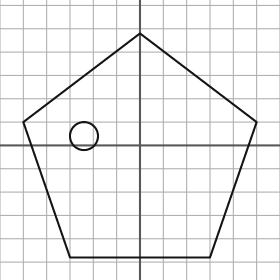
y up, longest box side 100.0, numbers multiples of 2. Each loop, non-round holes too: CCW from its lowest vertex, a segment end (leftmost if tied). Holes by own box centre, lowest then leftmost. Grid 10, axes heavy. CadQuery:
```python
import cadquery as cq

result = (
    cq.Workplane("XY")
    .moveTo(-30.0, -48.0)
    .lineTo(30.0, -48.0)
    .lineTo(50.0, 10.0)
    .lineTo(0.0, 48.0)
    .lineTo(-50.0, 10.0)
    .close()
    .moveTo(-24.0, 4.0)
    .circle(6.0)
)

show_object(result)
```